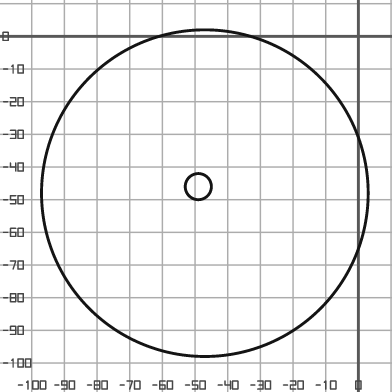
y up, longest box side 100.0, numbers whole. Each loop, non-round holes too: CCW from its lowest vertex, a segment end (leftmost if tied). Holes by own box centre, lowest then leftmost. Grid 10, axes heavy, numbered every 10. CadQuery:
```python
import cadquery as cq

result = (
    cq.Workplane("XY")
    .moveTo(-47.0, -48.0)
    .circle(50.0)
    .moveTo(-49.0, -46.0)
    .circle(4.0)
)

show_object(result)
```